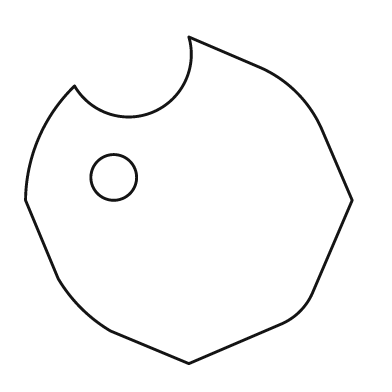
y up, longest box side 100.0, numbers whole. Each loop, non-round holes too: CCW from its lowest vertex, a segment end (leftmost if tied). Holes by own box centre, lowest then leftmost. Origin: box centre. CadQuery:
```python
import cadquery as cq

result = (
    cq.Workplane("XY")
    .moveTo(0.0, -50.0)
    .lineTo(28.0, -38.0)
    .threePointArc((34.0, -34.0), (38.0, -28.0))
    .lineTo(50.0, 0.0)
    .lineTo(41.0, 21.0)
    .threePointArc((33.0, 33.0), (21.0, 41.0))
    .lineTo(0.0, 50.0)
    .threePointArc((-11.0, 27.0), (-35.0, 35.0))
    .threePointArc((-46.0, 19.0), (-50.0, 0.0))
    .lineTo(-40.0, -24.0)
    .threePointArc((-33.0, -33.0), (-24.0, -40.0))
    .close()
    .moveTo(-23.0, 7.0)
    .circle(7.0)
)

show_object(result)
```